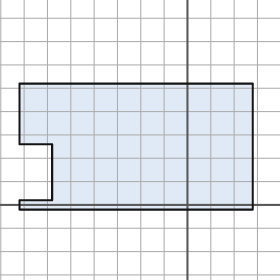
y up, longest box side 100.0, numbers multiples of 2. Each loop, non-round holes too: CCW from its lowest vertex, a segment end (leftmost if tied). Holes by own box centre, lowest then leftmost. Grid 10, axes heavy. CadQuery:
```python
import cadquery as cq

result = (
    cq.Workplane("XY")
    .moveTo(-72.0, -2.0)
    .lineTo(28.0, -2.0)
    .lineTo(28.0, 52.0)
    .lineTo(-72.0, 52.0)
    .lineTo(-72.0, 26.0)
    .lineTo(-58.0, 26.0)
    .lineTo(-58.0, 2.0)
    .lineTo(-72.0, 2.0)
    .close()
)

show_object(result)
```